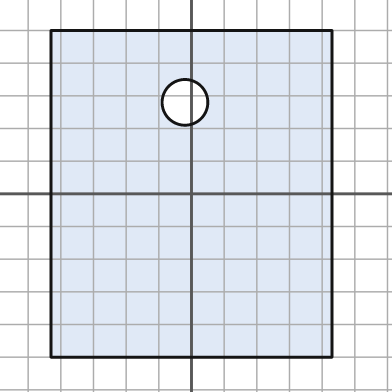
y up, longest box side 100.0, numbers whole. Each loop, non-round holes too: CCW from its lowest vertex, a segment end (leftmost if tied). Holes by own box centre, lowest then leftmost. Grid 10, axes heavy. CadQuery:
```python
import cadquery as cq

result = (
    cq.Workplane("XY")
    .moveTo(-43.0, -50.0)
    .lineTo(43.0, -50.0)
    .lineTo(43.0, 50.0)
    .lineTo(-43.0, 50.0)
    .close()
    .moveTo(-2.0, 28.0)
    .circle(7.0)
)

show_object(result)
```